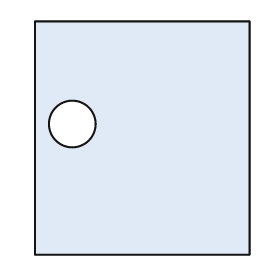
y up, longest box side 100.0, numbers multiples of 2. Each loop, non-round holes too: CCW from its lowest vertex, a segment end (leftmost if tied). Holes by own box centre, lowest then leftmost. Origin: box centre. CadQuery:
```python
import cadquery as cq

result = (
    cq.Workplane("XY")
    .moveTo(-46.0, -50.0)
    .lineTo(46.0, -50.0)
    .lineTo(46.0, 50.0)
    .lineTo(-46.0, 50.0)
    .close()
    .moveTo(-30.0, 6.0)
    .circle(10.0)
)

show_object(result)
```